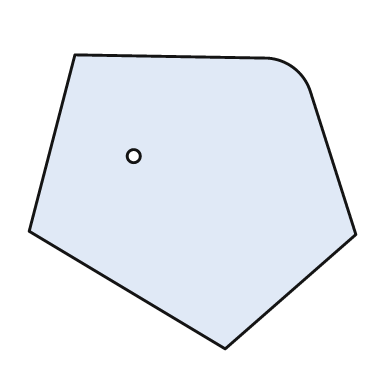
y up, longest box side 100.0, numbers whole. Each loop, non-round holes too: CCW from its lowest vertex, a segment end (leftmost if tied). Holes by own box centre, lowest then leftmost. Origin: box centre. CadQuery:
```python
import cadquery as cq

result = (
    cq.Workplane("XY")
    .moveTo(10.0, -45.0)
    .lineTo(50.0, -10.0)
    .lineTo(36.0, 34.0)
    .threePointArc((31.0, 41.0), (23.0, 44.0))
    .lineTo(-36.0, 45.0)
    .lineTo(-50.0, -9.0)
    .close()
    .moveTo(-18.0, 14.0)
    .circle(2.0)
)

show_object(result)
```